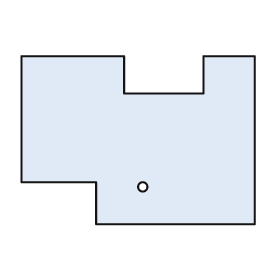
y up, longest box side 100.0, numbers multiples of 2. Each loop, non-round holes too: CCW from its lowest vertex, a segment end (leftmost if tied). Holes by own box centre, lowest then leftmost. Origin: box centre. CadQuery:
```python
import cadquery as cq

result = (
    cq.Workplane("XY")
    .moveTo(-18.0, -36.0)
    .lineTo(50.0, -36.0)
    .lineTo(50.0, 36.0)
    .lineTo(28.0, 36.0)
    .lineTo(28.0, 20.0)
    .lineTo(-6.0, 20.0)
    .lineTo(-6.0, 36.0)
    .lineTo(-50.0, 36.0)
    .lineTo(-50.0, -18.0)
    .lineTo(-18.0, -18.0)
    .close()
    .moveTo(2.0, -20.0)
    .circle(2.0)
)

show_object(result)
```